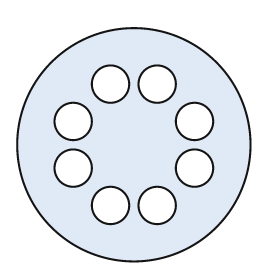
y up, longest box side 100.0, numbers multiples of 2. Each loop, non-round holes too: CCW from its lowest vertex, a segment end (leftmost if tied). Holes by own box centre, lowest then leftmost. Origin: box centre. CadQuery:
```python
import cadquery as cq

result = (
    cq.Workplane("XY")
    .moveTo(0.0, 0.0)
    .circle(50.0)
    .moveTo(-10.0, -26.0)
    .circle(8.0)
    .moveTo(10.0, -26.0)
    .circle(8.0)
    .moveTo(-26.0, -10.0)
    .circle(8.0)
    .moveTo(26.0, -10.0)
    .circle(8.0)
    .moveTo(-26.0, 10.0)
    .circle(8.0)
    .moveTo(26.0, 10.0)
    .circle(8.0)
    .moveTo(-10.0, 26.0)
    .circle(8.0)
    .moveTo(10.0, 26.0)
    .circle(8.0)
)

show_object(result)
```